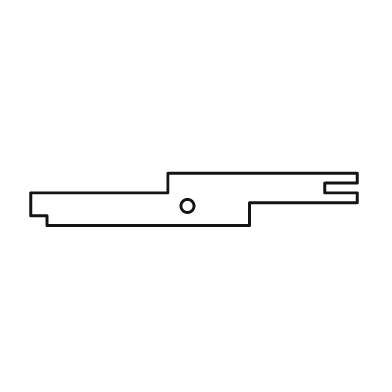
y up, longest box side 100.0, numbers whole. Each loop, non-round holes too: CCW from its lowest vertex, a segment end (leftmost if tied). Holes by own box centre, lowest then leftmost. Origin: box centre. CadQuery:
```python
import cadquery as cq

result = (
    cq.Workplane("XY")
    .moveTo(-45.0, -8.0)
    .lineTo(17.0, -8.0)
    .lineTo(17.0, -1.0)
    .lineTo(50.0, -1.0)
    .lineTo(50.0, 2.0)
    .lineTo(40.0, 2.0)
    .lineTo(40.0, 5.0)
    .lineTo(50.0, 5.0)
    .lineTo(50.0, 8.0)
    .lineTo(-8.0, 8.0)
    .lineTo(-8.0, 2.0)
    .lineTo(-50.0, 2.0)
    .lineTo(-50.0, -5.0)
    .lineTo(-45.0, -5.0)
    .close()
    .moveTo(-2.0, -2.0)
    .circle(2.0)
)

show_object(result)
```